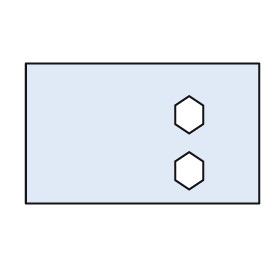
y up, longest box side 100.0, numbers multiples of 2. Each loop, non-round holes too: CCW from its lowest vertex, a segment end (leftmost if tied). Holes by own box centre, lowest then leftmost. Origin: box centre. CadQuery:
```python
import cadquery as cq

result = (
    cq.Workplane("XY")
    .moveTo(-50.0, -30.0)
    .lineTo(50.0, -30.0)
    .lineTo(50.0, 30.0)
    .lineTo(-50.0, 30.0)
    .close()
    .moveTo(20.0, -24.0)
    .lineTo(26.0, -20.0)
    .lineTo(26.0, -12.0)
    .lineTo(20.0, -8.0)
    .lineTo(14.0, -12.0)
    .lineTo(14.0, -20.0)
    .close()
    .moveTo(20.0, 0.0)
    .lineTo(26.0, 4.0)
    .lineTo(26.0, 12.0)
    .lineTo(20.0, 16.0)
    .lineTo(14.0, 12.0)
    .lineTo(14.0, 4.0)
    .close()
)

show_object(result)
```